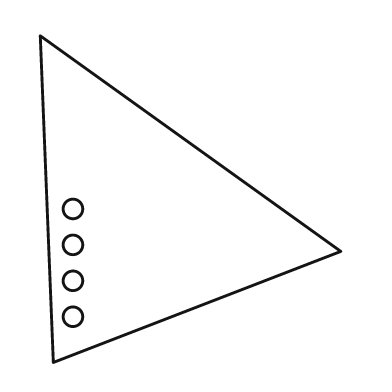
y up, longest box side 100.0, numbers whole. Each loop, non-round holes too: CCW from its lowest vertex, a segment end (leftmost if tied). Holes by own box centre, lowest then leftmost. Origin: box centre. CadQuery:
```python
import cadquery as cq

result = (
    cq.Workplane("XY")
    .moveTo(-42.0, -50.0)
    .lineTo(46.0, -16.0)
    .lineTo(-46.0, 50.0)
    .close()
    .moveTo(-36.0, -36.0)
    .circle(3.0)
    .moveTo(-36.0, -25.0)
    .circle(3.0)
    .moveTo(-36.0, -14.0)
    .circle(3.0)
    .moveTo(-36.0, -3.0)
    .circle(3.0)
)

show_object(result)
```